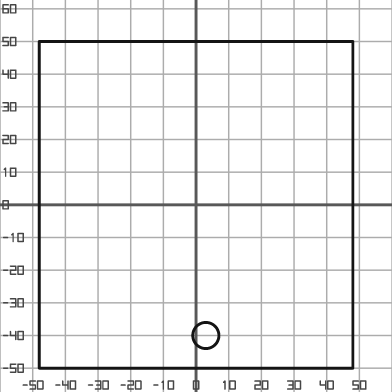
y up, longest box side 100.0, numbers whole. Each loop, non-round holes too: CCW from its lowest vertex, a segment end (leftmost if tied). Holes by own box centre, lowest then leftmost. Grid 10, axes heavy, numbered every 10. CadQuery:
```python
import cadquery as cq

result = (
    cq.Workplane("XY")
    .moveTo(-48.0, -50.0)
    .lineTo(48.0, -50.0)
    .lineTo(48.0, 50.0)
    .lineTo(-48.0, 50.0)
    .close()
    .moveTo(3.0, -40.0)
    .circle(4.0)
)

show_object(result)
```